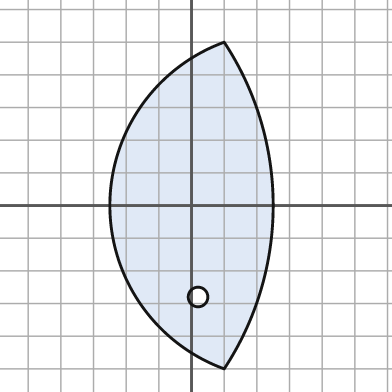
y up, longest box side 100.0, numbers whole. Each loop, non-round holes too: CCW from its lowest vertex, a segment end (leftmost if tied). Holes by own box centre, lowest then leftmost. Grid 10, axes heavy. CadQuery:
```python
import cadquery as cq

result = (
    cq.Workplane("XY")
    .moveTo(10.0, -50.0)
    .threePointArc((25.0, 0.0), (10.0, 50.0))
    .threePointArc((-25.0, 0.0), (10.0, -50.0))
    .close()
    .moveTo(2.0, -28.0)
    .circle(3.0)
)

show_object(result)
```